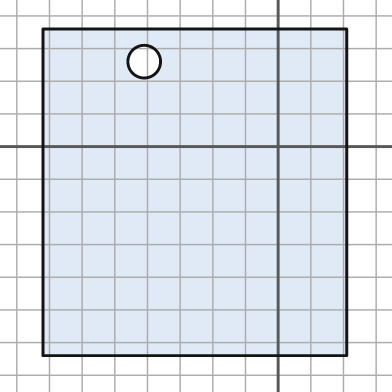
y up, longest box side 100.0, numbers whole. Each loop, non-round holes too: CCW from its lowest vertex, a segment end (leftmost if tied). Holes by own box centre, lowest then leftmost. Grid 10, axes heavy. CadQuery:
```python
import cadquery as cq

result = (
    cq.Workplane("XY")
    .moveTo(-72.0, -64.0)
    .lineTo(21.0, -64.0)
    .lineTo(21.0, 36.0)
    .lineTo(-72.0, 36.0)
    .close()
    .moveTo(-41.0, 26.0)
    .circle(5.0)
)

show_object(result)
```